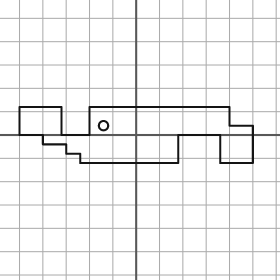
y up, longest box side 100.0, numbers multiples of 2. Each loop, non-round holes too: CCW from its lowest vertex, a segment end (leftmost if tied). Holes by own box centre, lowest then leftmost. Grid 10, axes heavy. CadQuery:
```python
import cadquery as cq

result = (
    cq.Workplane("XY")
    .moveTo(-24.0, -12.0)
    .lineTo(18.0, -12.0)
    .lineTo(18.0, 0.0)
    .lineTo(36.0, 0.0)
    .lineTo(36.0, -12.0)
    .lineTo(50.0, -12.0)
    .lineTo(50.0, 4.0)
    .lineTo(40.0, 4.0)
    .lineTo(40.0, 12.0)
    .lineTo(-20.0, 12.0)
    .lineTo(-20.0, 0.0)
    .lineTo(-32.0, 0.0)
    .lineTo(-32.0, 12.0)
    .lineTo(-50.0, 12.0)
    .lineTo(-50.0, 0.0)
    .lineTo(-40.0, 0.0)
    .lineTo(-40.0, -4.0)
    .lineTo(-30.0, -4.0)
    .lineTo(-30.0, -8.0)
    .lineTo(-24.0, -8.0)
    .close()
    .moveTo(-14.0, 4.0)
    .circle(2.0)
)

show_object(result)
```